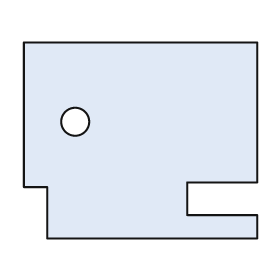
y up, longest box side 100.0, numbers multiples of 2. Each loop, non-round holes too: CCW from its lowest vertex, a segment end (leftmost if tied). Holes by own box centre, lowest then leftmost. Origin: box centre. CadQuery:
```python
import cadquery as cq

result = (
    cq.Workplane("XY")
    .moveTo(-40.0, -42.0)
    .lineTo(50.0, -42.0)
    .lineTo(50.0, -32.0)
    .lineTo(20.0, -32.0)
    .lineTo(20.0, -18.0)
    .lineTo(50.0, -18.0)
    .lineTo(50.0, 42.0)
    .lineTo(-50.0, 42.0)
    .lineTo(-50.0, -20.0)
    .lineTo(-40.0, -20.0)
    .close()
    .moveTo(-28.0, 8.0)
    .circle(6.0)
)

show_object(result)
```